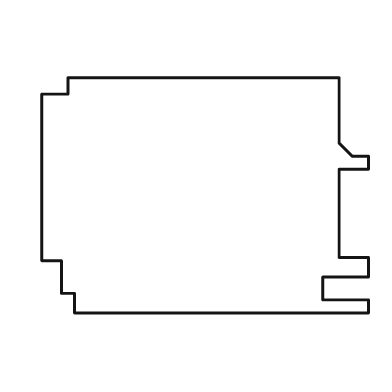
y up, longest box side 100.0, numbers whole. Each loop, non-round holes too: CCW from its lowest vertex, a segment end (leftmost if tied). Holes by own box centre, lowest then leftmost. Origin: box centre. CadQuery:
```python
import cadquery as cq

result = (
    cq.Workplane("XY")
    .moveTo(-40.0, -36.0)
    .lineTo(50.0, -36.0)
    .lineTo(50.0, -32.0)
    .lineTo(36.0, -32.0)
    .lineTo(36.0, -25.0)
    .lineTo(50.0, -25.0)
    .lineTo(50.0, -19.0)
    .lineTo(41.0, -19.0)
    .lineTo(41.0, 8.0)
    .lineTo(50.0, 8.0)
    .lineTo(50.0, 12.0)
    .lineTo(45.0, 12.0)
    .lineTo(41.0, 16.0)
    .lineTo(41.0, 36.0)
    .lineTo(-42.0, 36.0)
    .lineTo(-42.0, 31.0)
    .lineTo(-50.0, 31.0)
    .lineTo(-50.0, -20.0)
    .lineTo(-44.0, -20.0)
    .lineTo(-44.0, -30.0)
    .lineTo(-40.0, -30.0)
    .close()
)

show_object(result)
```